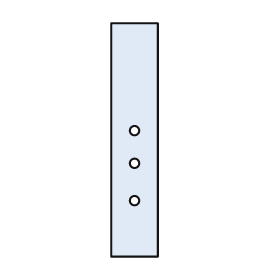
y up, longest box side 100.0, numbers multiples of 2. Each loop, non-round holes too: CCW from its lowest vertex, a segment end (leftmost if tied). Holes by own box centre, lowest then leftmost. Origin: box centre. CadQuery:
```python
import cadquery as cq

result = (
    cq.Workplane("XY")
    .moveTo(-10.0, -50.0)
    .lineTo(10.0, -50.0)
    .lineTo(10.0, 50.0)
    .lineTo(-10.0, 50.0)
    .close()
    .moveTo(0.0, -26.0)
    .circle(2.0)
    .moveTo(0.0, -10.0)
    .circle(2.0)
    .moveTo(0.0, 4.0)
    .circle(2.0)
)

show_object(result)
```